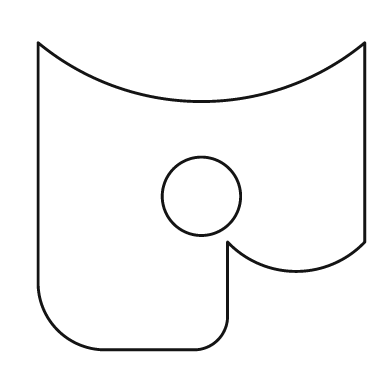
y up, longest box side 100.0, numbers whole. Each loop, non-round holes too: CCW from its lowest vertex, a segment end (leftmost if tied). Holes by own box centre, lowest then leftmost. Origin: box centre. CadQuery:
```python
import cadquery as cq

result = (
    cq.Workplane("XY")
    .moveTo(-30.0, -47.0)
    .lineTo(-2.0, -47.0)
    .threePointArc((5.0, -44.0), (8.0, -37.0))
    .lineTo(8.0, -14.0)
    .threePointArc((29.0, -23.0), (50.0, -14.0))
    .lineTo(50.0, 47.0)
    .threePointArc((0.0, 29.0), (-50.0, 47.0))
    .lineTo(-50.0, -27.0)
    .threePointArc((-44.0, -41.0), (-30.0, -47.0))
    .close()
    .moveTo(0.0, 0.0)
    .circle(12.0)
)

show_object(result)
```